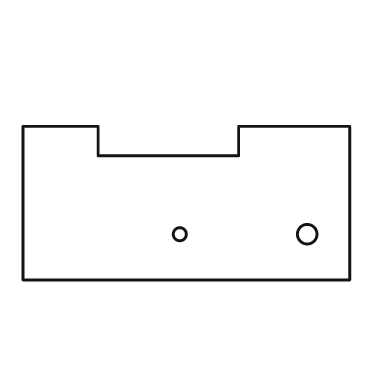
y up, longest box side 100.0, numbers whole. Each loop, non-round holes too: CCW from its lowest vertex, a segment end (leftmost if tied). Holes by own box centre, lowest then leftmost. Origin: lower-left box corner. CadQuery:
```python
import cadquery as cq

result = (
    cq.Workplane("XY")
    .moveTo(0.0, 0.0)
    .lineTo(100.0, 0.0)
    .lineTo(100.0, 47.0)
    .lineTo(66.0, 47.0)
    .lineTo(66.0, 38.0)
    .lineTo(23.0, 38.0)
    .lineTo(23.0, 47.0)
    .lineTo(0.0, 47.0)
    .close()
    .moveTo(48.0, 14.0)
    .circle(2.0)
    .moveTo(87.0, 14.0)
    .circle(3.0)
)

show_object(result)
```